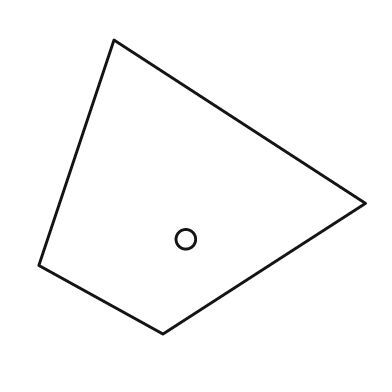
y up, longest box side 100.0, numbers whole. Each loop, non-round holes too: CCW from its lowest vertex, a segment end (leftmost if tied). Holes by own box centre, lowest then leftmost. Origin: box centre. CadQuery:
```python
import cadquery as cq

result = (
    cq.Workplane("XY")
    .moveTo(-12.0, -45.0)
    .lineTo(50.0, -5.0)
    .lineTo(-27.0, 45.0)
    .lineTo(-50.0, -24.0)
    .close()
    .moveTo(-5.0, -16.0)
    .circle(3.0)
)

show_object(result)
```